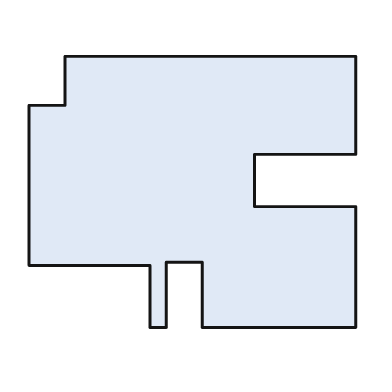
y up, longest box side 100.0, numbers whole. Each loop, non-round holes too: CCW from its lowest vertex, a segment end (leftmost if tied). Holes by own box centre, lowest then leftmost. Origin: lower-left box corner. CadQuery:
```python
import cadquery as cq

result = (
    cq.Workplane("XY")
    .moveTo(37.0, 0.0)
    .lineTo(42.0, 0.0)
    .lineTo(42.0, 20.0)
    .lineTo(53.0, 20.0)
    .lineTo(53.0, 0.0)
    .lineTo(100.0, 0.0)
    .lineTo(100.0, 37.0)
    .lineTo(69.0, 37.0)
    .lineTo(69.0, 53.0)
    .lineTo(100.0, 53.0)
    .lineTo(100.0, 83.0)
    .lineTo(11.0, 83.0)
    .lineTo(11.0, 68.0)
    .lineTo(0.0, 68.0)
    .lineTo(0.0, 19.0)
    .lineTo(37.0, 19.0)
    .close()
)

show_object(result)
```